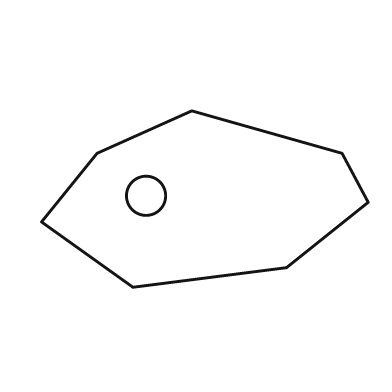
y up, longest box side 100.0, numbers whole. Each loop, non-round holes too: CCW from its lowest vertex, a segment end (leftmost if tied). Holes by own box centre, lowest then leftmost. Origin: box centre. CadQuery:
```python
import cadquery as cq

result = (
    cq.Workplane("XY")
    .moveTo(-22.0, -27.0)
    .lineTo(25.0, -21.0)
    .lineTo(50.0, -1.0)
    .lineTo(42.0, 14.0)
    .lineTo(-4.0, 27.0)
    .lineTo(-33.0, 14.0)
    .lineTo(-50.0, -7.0)
    .close()
    .moveTo(-18.0, 1.0)
    .circle(6.0)
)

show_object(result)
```